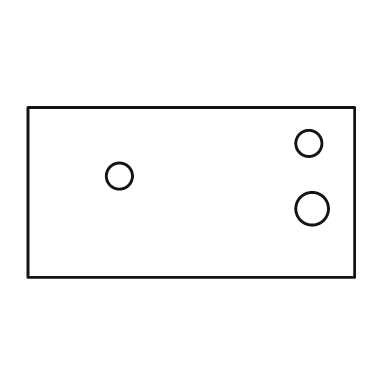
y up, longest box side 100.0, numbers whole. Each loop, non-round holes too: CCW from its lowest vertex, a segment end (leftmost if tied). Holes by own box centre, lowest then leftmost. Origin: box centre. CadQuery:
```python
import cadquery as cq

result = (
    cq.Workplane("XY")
    .moveTo(-50.0, -26.0)
    .lineTo(50.0, -26.0)
    .lineTo(50.0, 26.0)
    .lineTo(-50.0, 26.0)
    .close()
    .moveTo(37.0, -5.0)
    .circle(5.0)
    .moveTo(-22.0, 5.0)
    .circle(4.0)
    .moveTo(36.0, 15.0)
    .circle(4.0)
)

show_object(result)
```